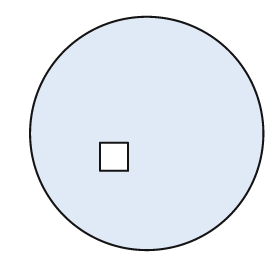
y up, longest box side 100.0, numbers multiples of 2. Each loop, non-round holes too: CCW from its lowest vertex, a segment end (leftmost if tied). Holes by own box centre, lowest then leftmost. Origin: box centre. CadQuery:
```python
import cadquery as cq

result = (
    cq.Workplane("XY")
    .moveTo(0.0, 0.0)
    .circle(50.0)
    .moveTo(-20.0, -16.0)
    .lineTo(-8.0, -16.0)
    .lineTo(-8.0, -4.0)
    .lineTo(-20.0, -4.0)
    .close()
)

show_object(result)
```